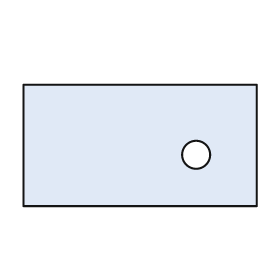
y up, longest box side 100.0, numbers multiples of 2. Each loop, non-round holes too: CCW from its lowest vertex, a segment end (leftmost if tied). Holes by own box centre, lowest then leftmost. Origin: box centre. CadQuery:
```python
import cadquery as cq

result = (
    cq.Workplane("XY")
    .moveTo(-50.0, -26.0)
    .lineTo(50.0, -26.0)
    .lineTo(50.0, 26.0)
    .lineTo(-50.0, 26.0)
    .close()
    .moveTo(24.0, -4.0)
    .circle(6.0)
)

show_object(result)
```